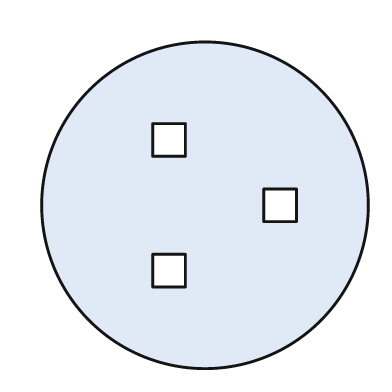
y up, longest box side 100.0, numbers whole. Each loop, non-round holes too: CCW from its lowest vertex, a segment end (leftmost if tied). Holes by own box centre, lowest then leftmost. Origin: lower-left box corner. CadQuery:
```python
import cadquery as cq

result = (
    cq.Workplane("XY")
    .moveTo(50.0, 50.0)
    .circle(50.0)
    .moveTo(34.0, 25.0)
    .lineTo(44.0, 25.0)
    .lineTo(44.0, 35.0)
    .lineTo(34.0, 35.0)
    .close()
    .moveTo(68.0, 45.0)
    .lineTo(78.0, 45.0)
    .lineTo(78.0, 55.0)
    .lineTo(68.0, 55.0)
    .close()
    .moveTo(34.0, 65.0)
    .lineTo(44.0, 65.0)
    .lineTo(44.0, 75.0)
    .lineTo(34.0, 75.0)
    .close()
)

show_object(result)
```